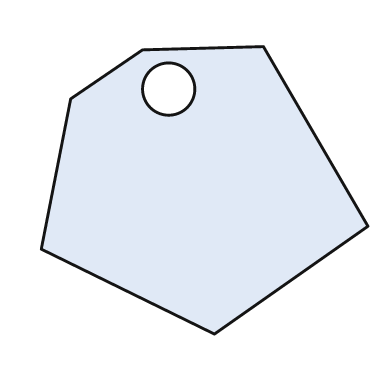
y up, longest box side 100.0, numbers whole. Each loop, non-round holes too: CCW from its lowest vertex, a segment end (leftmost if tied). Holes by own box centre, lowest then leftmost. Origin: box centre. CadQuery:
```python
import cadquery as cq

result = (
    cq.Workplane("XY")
    .moveTo(3.0, -44.0)
    .lineTo(50.0, -11.0)
    .lineTo(18.0, 44.0)
    .lineTo(-19.0, 43.0)
    .lineTo(-41.0, 28.0)
    .lineTo(-50.0, -18.0)
    .close()
    .moveTo(-11.0, 31.0)
    .circle(8.0)
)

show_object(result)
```